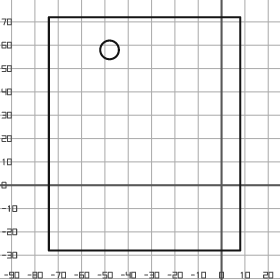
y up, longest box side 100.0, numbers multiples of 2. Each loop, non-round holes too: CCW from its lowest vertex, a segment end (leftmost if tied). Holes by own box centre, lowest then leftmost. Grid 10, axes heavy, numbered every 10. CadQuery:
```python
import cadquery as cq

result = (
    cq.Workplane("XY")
    .moveTo(-74.0, -28.0)
    .lineTo(8.0, -28.0)
    .lineTo(8.0, 72.0)
    .lineTo(-74.0, 72.0)
    .close()
    .moveTo(-48.0, 58.0)
    .circle(4.0)
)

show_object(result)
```